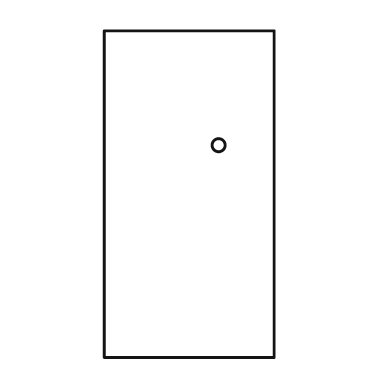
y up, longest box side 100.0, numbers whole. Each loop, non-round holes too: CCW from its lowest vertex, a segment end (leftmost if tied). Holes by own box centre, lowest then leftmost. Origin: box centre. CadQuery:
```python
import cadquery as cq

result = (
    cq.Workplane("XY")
    .moveTo(-26.0, -50.0)
    .lineTo(26.0, -50.0)
    .lineTo(26.0, 50.0)
    .lineTo(-26.0, 50.0)
    .close()
    .moveTo(9.0, 15.0)
    .circle(2.0)
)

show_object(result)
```